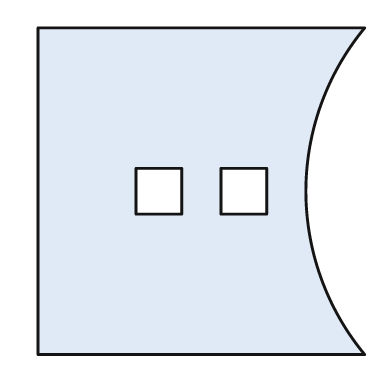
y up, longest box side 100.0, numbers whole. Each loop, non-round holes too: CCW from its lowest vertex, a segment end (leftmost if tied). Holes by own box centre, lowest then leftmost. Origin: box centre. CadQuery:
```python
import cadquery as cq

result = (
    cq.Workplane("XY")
    .moveTo(-50.0, -50.0)
    .lineTo(50.0, -50.0)
    .threePointArc((32.0, 0.0), (50.0, 50.0))
    .lineTo(-50.0, 50.0)
    .close()
    .moveTo(-20.0, -7.0)
    .lineTo(-6.0, -7.0)
    .lineTo(-6.0, 7.0)
    .lineTo(-20.0, 7.0)
    .close()
    .moveTo(6.0, -7.0)
    .lineTo(20.0, -7.0)
    .lineTo(20.0, 7.0)
    .lineTo(6.0, 7.0)
    .close()
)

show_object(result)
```